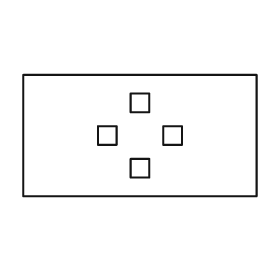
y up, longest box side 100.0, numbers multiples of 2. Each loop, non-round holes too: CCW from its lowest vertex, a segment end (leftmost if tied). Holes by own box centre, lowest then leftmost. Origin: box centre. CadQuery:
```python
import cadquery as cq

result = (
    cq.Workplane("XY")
    .moveTo(-50.0, -26.0)
    .lineTo(50.0, -26.0)
    .lineTo(50.0, 26.0)
    .lineTo(-50.0, 26.0)
    .close()
    .moveTo(-4.0, -18.0)
    .lineTo(4.0, -18.0)
    .lineTo(4.0, -10.0)
    .lineTo(-4.0, -10.0)
    .close()
    .moveTo(-18.0, -4.0)
    .lineTo(-10.0, -4.0)
    .lineTo(-10.0, 4.0)
    .lineTo(-18.0, 4.0)
    .close()
    .moveTo(10.0, -4.0)
    .lineTo(18.0, -4.0)
    .lineTo(18.0, 4.0)
    .lineTo(10.0, 4.0)
    .close()
    .moveTo(-4.0, 10.0)
    .lineTo(4.0, 10.0)
    .lineTo(4.0, 18.0)
    .lineTo(-4.0, 18.0)
    .close()
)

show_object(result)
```